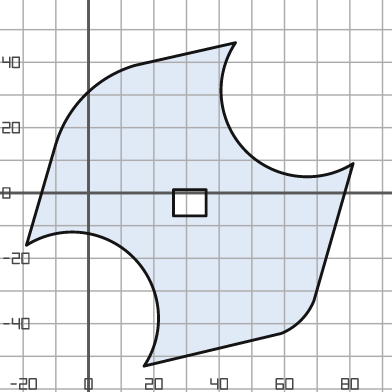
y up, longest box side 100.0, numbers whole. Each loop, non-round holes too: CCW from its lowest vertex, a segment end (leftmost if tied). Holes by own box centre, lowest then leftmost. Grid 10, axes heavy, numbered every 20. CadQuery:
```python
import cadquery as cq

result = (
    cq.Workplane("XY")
    .moveTo(17.0, -53.0)
    .lineTo(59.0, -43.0)
    .threePointArc((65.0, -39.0), (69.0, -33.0))
    .lineTo(81.0, 9.0)
    .threePointArc((48.0, 13.0), (45.0, 46.0))
    .lineTo(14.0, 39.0)
    .threePointArc((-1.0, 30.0), (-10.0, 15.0))
    .lineTo(-19.0, -16.0)
    .threePointArc((14.0, -20.0), (17.0, -53.0))
    .close()
    .moveTo(26.0, -7.0)
    .lineTo(36.0, -7.0)
    .lineTo(36.0, 1.0)
    .lineTo(26.0, 1.0)
    .close()
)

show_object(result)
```